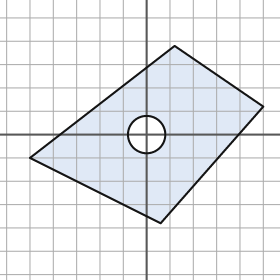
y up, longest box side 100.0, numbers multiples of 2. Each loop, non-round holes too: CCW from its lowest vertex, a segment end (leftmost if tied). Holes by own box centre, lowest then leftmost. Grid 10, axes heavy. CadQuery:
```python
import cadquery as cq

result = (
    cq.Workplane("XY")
    .moveTo(6.0, -38.0)
    .lineTo(50.0, 12.0)
    .lineTo(12.0, 38.0)
    .lineTo(-50.0, -10.0)
    .close()
    .moveTo(0.0, 0.0)
    .circle(8.0)
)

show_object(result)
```